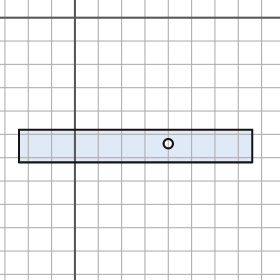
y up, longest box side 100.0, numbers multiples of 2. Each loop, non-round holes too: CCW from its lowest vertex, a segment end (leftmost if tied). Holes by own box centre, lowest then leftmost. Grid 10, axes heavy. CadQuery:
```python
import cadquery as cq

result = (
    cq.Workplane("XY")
    .moveTo(-24.0, -62.0)
    .lineTo(76.0, -62.0)
    .lineTo(76.0, -48.0)
    .lineTo(-24.0, -48.0)
    .close()
    .moveTo(40.0, -54.0)
    .circle(2.0)
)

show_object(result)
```